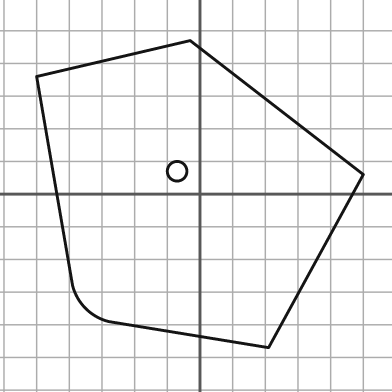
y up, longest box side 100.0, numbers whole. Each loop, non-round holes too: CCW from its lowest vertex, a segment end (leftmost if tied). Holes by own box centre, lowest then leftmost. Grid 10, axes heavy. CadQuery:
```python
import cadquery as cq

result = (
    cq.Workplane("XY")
    .moveTo(21.0, -47.0)
    .lineTo(50.0, 6.0)
    .lineTo(-3.0, 47.0)
    .lineTo(-50.0, 36.0)
    .lineTo(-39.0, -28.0)
    .threePointArc((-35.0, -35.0), (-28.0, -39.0))
    .close()
    .moveTo(-7.0, 7.0)
    .circle(3.0)
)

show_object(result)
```